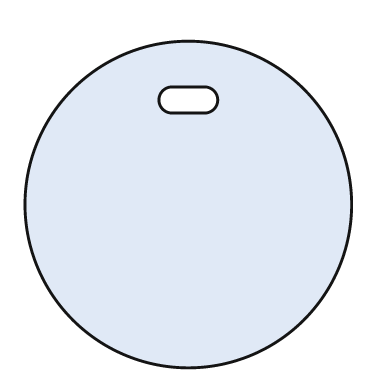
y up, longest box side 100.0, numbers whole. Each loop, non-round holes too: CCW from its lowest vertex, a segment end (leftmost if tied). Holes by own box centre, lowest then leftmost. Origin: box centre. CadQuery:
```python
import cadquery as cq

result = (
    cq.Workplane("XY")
    .moveTo(0.0, 0.0)
    .circle(50.0)
    .moveTo(-5.0, 28.0)
    .lineTo(5.0, 28.0)
    .threePointArc((9.0, 32.0), (5.0, 36.0))
    .lineTo(-5.0, 36.0)
    .threePointArc((-9.0, 32.0), (-5.0, 28.0))
    .close()
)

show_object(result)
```